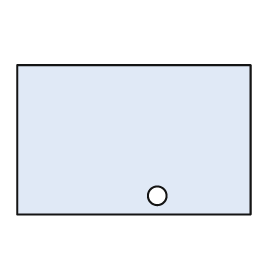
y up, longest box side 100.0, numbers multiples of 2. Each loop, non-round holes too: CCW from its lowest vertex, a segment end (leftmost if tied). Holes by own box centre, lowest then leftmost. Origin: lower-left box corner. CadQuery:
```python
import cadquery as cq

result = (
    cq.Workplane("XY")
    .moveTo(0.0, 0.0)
    .lineTo(100.0, 0.0)
    .lineTo(100.0, 64.0)
    .lineTo(0.0, 64.0)
    .close()
    .moveTo(60.0, 8.0)
    .circle(4.0)
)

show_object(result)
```